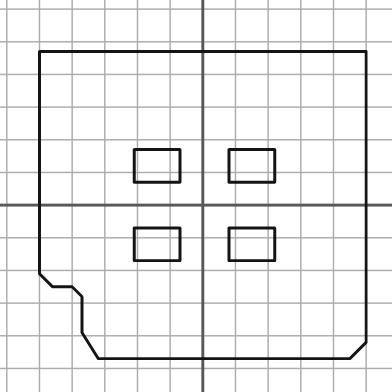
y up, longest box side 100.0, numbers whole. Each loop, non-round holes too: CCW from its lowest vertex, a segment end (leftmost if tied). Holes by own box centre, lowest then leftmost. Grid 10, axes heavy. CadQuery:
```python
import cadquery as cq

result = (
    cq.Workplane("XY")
    .moveTo(-32.0, -47.0)
    .lineTo(45.0, -47.0)
    .lineTo(50.0, -42.0)
    .lineTo(50.0, 47.0)
    .lineTo(-50.0, 47.0)
    .lineTo(-50.0, -21.0)
    .lineTo(-46.0, -25.0)
    .lineTo(-40.0, -25.0)
    .lineTo(-37.0, -28.0)
    .lineTo(-37.0, -39.0)
    .close()
    .moveTo(-21.0, -17.0)
    .lineTo(-7.0, -17.0)
    .lineTo(-7.0, -7.0)
    .lineTo(-21.0, -7.0)
    .close()
    .moveTo(8.0, -17.0)
    .lineTo(22.0, -17.0)
    .lineTo(22.0, -7.0)
    .lineTo(8.0, -7.0)
    .close()
    .moveTo(-21.0, 7.0)
    .lineTo(-7.0, 7.0)
    .lineTo(-7.0, 17.0)
    .lineTo(-21.0, 17.0)
    .close()
    .moveTo(8.0, 7.0)
    .lineTo(22.0, 7.0)
    .lineTo(22.0, 17.0)
    .lineTo(8.0, 17.0)
    .close()
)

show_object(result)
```